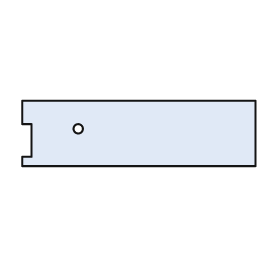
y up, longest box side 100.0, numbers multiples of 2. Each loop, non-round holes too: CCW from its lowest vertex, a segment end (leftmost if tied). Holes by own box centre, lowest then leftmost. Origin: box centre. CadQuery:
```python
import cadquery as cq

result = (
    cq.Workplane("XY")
    .moveTo(-50.0, -14.0)
    .lineTo(50.0, -14.0)
    .lineTo(50.0, 14.0)
    .lineTo(-50.0, 14.0)
    .lineTo(-50.0, 4.0)
    .lineTo(-46.0, 4.0)
    .lineTo(-46.0, -10.0)
    .lineTo(-50.0, -10.0)
    .close()
    .moveTo(-26.0, 2.0)
    .circle(2.0)
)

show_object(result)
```